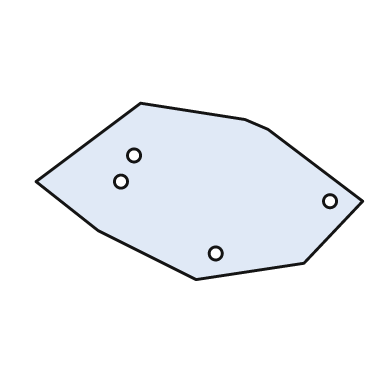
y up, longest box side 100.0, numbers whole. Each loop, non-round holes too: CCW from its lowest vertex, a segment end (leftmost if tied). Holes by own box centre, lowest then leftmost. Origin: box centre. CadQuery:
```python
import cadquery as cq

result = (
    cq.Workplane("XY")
    .moveTo(-1.0, -27.0)
    .lineTo(32.0, -22.0)
    .lineTo(50.0, -3.0)
    .lineTo(21.0, 19.0)
    .lineTo(14.0, 22.0)
    .lineTo(-18.0, 27.0)
    .lineTo(-50.0, 3.0)
    .lineTo(-31.0, -12.0)
    .close()
    .moveTo(5.0, -19.0)
    .circle(2.0)
    .moveTo(40.0, -3.0)
    .circle(2.0)
    .moveTo(-24.0, 3.0)
    .circle(2.0)
    .moveTo(-20.0, 11.0)
    .circle(2.0)
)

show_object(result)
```